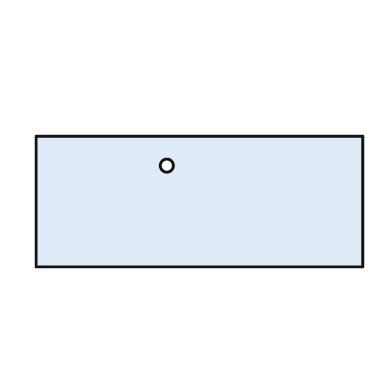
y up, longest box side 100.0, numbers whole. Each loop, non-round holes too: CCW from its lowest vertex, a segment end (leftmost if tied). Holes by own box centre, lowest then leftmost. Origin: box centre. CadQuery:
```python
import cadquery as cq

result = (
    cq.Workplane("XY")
    .moveTo(-50.0, -20.0)
    .lineTo(50.0, -20.0)
    .lineTo(50.0, 20.0)
    .lineTo(-50.0, 20.0)
    .close()
    .moveTo(-10.0, 11.0)
    .circle(2.0)
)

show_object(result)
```